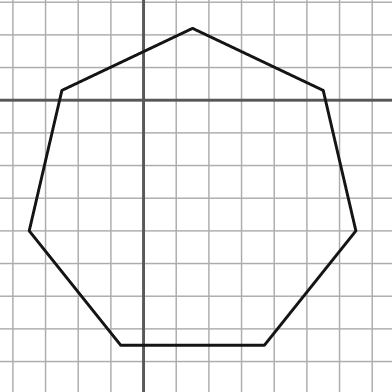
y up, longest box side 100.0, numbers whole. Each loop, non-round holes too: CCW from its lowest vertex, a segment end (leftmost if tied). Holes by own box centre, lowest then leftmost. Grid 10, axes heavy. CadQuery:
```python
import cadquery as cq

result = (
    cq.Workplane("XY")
    .moveTo(-7.0, -75.0)
    .lineTo(37.0, -75.0)
    .lineTo(65.0, -40.0)
    .lineTo(55.0, 3.0)
    .lineTo(15.0, 22.0)
    .lineTo(-25.0, 3.0)
    .lineTo(-35.0, -40.0)
    .close()
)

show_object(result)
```